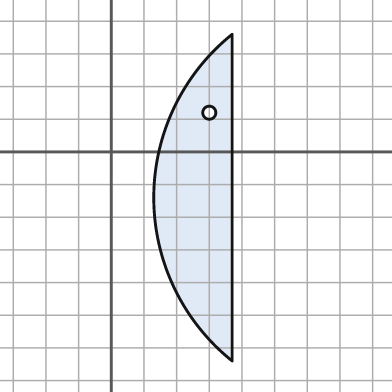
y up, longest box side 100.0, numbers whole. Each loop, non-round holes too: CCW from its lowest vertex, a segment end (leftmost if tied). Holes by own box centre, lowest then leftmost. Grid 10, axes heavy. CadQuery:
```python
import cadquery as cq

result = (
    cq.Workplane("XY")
    .moveTo(37.0, -64.0)
    .lineTo(37.0, 36.0)
    .threePointArc((13.0, -14.0), (37.0, -64.0))
    .close()
    .moveTo(30.0, 12.0)
    .circle(2.0)
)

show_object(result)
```